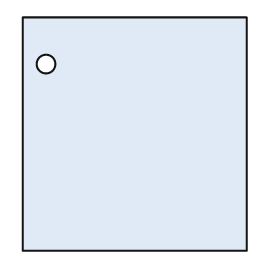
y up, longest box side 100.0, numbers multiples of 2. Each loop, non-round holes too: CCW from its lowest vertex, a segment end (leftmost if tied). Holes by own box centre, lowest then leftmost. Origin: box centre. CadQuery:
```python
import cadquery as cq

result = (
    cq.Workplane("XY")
    .moveTo(-48.0, -50.0)
    .lineTo(48.0, -50.0)
    .lineTo(48.0, 50.0)
    .lineTo(-48.0, 50.0)
    .close()
    .moveTo(-38.0, 30.0)
    .circle(4.0)
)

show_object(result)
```